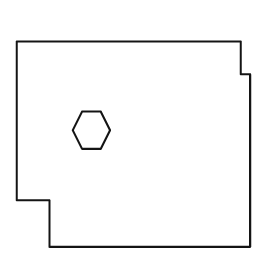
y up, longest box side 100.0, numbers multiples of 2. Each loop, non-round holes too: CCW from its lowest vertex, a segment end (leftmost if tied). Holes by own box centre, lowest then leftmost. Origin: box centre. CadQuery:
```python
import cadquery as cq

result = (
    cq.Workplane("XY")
    .moveTo(-36.0, -44.0)
    .lineTo(50.0, -44.0)
    .lineTo(50.0, 30.0)
    .lineTo(46.0, 30.0)
    .lineTo(46.0, 44.0)
    .lineTo(-50.0, 44.0)
    .lineTo(-50.0, -24.0)
    .lineTo(-36.0, -24.0)
    .close()
    .moveTo(-22.0, -2.0)
    .lineTo(-14.0, -2.0)
    .lineTo(-10.0, 6.0)
    .lineTo(-14.0, 14.0)
    .lineTo(-22.0, 14.0)
    .lineTo(-26.0, 6.0)
    .close()
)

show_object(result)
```